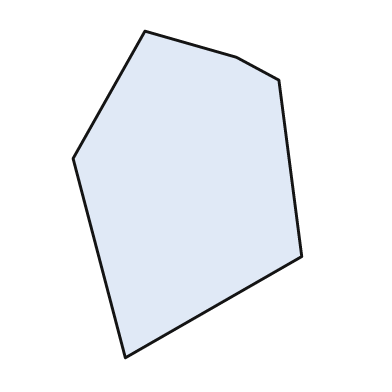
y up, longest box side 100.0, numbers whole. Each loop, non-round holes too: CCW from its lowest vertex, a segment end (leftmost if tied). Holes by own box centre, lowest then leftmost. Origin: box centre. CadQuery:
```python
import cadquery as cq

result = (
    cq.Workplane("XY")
    .moveTo(-19.0, -50.0)
    .lineTo(35.0, -19.0)
    .lineTo(28.0, 35.0)
    .lineTo(15.0, 42.0)
    .lineTo(-13.0, 50.0)
    .lineTo(-35.0, 11.0)
    .close()
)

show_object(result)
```